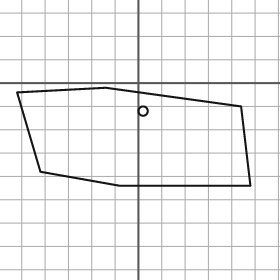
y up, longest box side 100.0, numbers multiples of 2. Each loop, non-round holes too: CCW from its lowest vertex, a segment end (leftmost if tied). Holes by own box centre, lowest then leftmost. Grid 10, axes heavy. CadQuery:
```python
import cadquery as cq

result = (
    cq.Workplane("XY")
    .moveTo(-8.0, -44.0)
    .lineTo(48.0, -44.0)
    .lineTo(44.0, -10.0)
    .lineTo(-14.0, -2.0)
    .lineTo(-52.0, -4.0)
    .lineTo(-42.0, -38.0)
    .close()
    .moveTo(2.0, -12.0)
    .circle(2.0)
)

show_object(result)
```